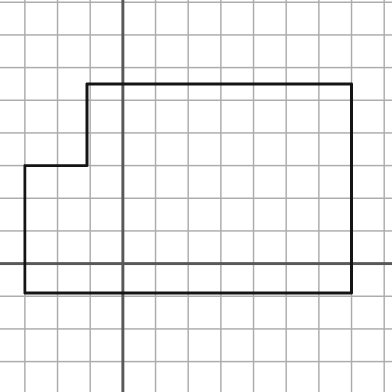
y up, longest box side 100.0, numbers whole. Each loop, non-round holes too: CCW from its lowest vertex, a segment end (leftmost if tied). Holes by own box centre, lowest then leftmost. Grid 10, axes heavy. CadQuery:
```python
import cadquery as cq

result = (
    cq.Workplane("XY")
    .moveTo(-30.0, -9.0)
    .lineTo(70.0, -9.0)
    .lineTo(70.0, 55.0)
    .lineTo(-11.0, 55.0)
    .lineTo(-11.0, 30.0)
    .lineTo(-30.0, 30.0)
    .close()
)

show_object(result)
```